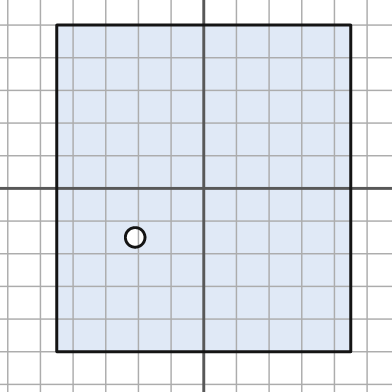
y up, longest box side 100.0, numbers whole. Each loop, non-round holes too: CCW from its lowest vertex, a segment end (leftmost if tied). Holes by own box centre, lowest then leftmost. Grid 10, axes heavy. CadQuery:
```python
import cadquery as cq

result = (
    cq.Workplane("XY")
    .moveTo(-45.0, -50.0)
    .lineTo(45.0, -50.0)
    .lineTo(45.0, 50.0)
    .lineTo(-45.0, 50.0)
    .close()
    .moveTo(-21.0, -15.0)
    .circle(3.0)
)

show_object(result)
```